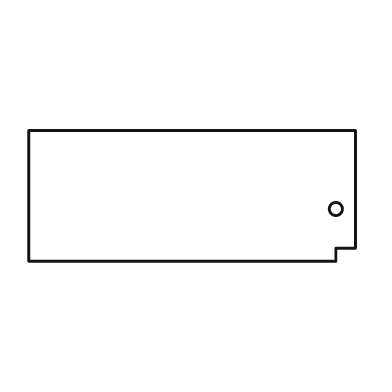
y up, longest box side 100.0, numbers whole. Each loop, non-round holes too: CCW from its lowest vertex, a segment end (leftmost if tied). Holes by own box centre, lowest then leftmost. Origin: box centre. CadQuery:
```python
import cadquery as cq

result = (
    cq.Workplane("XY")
    .moveTo(-50.0, -20.0)
    .lineTo(44.0, -20.0)
    .lineTo(44.0, -16.0)
    .lineTo(50.0, -16.0)
    .lineTo(50.0, 20.0)
    .lineTo(-50.0, 20.0)
    .close()
    .moveTo(44.0, -4.0)
    .circle(2.0)
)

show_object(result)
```